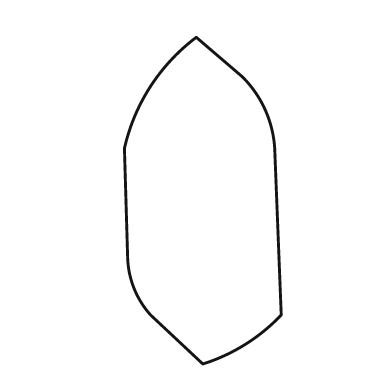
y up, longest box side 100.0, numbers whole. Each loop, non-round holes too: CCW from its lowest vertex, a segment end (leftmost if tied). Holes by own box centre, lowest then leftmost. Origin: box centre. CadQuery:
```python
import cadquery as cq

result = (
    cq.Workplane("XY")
    .moveTo(0.0, -50.0)
    .threePointArc((13.0, -44.0), (24.0, -35.0))
    .lineTo(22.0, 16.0)
    .threePointArc((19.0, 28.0), (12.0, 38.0))
    .lineTo(-2.0, 50.0)
    .threePointArc((-16.0, 35.0), (-24.0, 16.0))
    .lineTo(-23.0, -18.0)
    .threePointArc((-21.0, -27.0), (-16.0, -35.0))
    .close()
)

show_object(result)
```